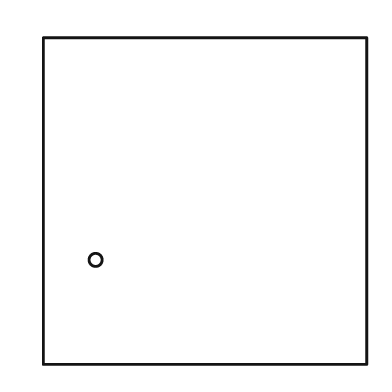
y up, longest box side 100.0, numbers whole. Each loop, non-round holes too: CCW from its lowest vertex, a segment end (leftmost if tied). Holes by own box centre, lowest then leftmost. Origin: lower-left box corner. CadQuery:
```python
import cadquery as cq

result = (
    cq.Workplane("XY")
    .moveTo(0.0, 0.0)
    .lineTo(99.0, 0.0)
    .lineTo(99.0, 100.0)
    .lineTo(0.0, 100.0)
    .close()
    .moveTo(16.0, 32.0)
    .circle(2.0)
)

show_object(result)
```